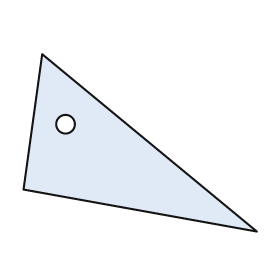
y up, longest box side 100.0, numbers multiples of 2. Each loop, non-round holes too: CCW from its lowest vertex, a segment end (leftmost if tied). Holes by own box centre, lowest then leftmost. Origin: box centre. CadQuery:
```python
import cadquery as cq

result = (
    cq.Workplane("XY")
    .moveTo(50.0, -38.0)
    .lineTo(-42.0, 38.0)
    .lineTo(-50.0, -20.0)
    .close()
    .moveTo(-32.0, 8.0)
    .circle(4.0)
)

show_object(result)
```